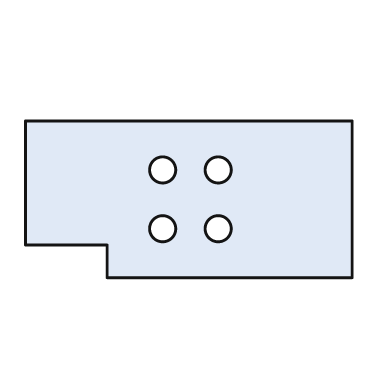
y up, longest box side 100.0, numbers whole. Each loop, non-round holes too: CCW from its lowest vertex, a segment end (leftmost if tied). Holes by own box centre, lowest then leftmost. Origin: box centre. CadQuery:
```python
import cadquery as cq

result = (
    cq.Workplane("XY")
    .moveTo(-25.0, -24.0)
    .lineTo(50.0, -24.0)
    .lineTo(50.0, 24.0)
    .lineTo(-50.0, 24.0)
    .lineTo(-50.0, -14.0)
    .lineTo(-25.0, -14.0)
    .close()
    .moveTo(-8.0, -9.0)
    .circle(4.0)
    .moveTo(9.0, -9.0)
    .circle(4.0)
    .moveTo(-8.0, 9.0)
    .circle(4.0)
    .moveTo(9.0, 9.0)
    .circle(4.0)
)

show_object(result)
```